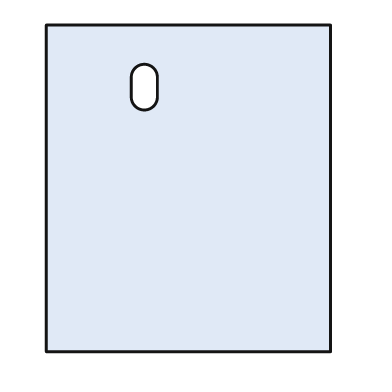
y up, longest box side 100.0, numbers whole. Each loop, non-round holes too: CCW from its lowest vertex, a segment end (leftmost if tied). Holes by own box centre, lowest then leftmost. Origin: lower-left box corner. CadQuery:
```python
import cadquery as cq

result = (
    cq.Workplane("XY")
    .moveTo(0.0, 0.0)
    .lineTo(87.0, 0.0)
    .lineTo(87.0, 100.0)
    .lineTo(0.0, 100.0)
    .close()
    .moveTo(26.0, 78.0)
    .threePointArc((30.0, 74.0), (34.0, 78.0))
    .lineTo(34.0, 84.0)
    .threePointArc((30.0, 88.0), (26.0, 84.0))
    .close()
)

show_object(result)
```